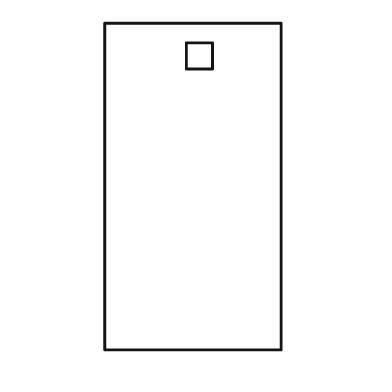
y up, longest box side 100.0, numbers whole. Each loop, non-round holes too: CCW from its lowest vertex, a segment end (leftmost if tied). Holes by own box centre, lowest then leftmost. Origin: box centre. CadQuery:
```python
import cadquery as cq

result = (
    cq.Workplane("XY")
    .moveTo(-27.0, -50.0)
    .lineTo(27.0, -50.0)
    .lineTo(27.0, 50.0)
    .lineTo(-27.0, 50.0)
    .close()
    .moveTo(-2.0, 36.0)
    .lineTo(6.0, 36.0)
    .lineTo(6.0, 44.0)
    .lineTo(-2.0, 44.0)
    .close()
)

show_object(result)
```